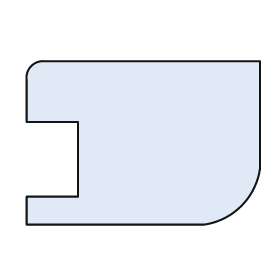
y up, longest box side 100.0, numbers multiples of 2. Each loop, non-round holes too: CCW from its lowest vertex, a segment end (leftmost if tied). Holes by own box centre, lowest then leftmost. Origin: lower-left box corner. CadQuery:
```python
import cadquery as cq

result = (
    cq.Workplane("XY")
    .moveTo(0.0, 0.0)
    .lineTo(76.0, 0.0)
    .threePointArc((92.0, 8.0), (100.0, 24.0))
    .lineTo(100.0, 70.0)
    .lineTo(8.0, 70.0)
    .threePointArc((2.0, 68.0), (0.0, 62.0))
    .lineTo(0.0, 44.0)
    .lineTo(22.0, 44.0)
    .lineTo(22.0, 12.0)
    .lineTo(0.0, 12.0)
    .close()
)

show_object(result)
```